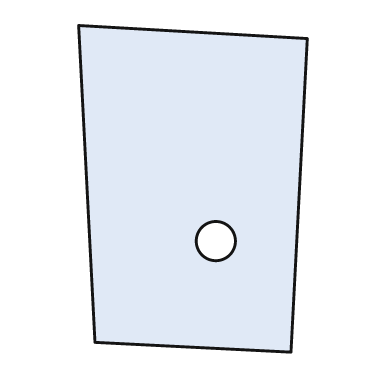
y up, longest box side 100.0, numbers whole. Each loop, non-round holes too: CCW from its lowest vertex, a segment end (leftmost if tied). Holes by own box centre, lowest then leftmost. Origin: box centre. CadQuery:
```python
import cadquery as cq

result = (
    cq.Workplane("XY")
    .moveTo(30.0, -50.0)
    .lineTo(35.0, 46.0)
    .lineTo(-35.0, 50.0)
    .lineTo(-30.0, -47.0)
    .close()
    .moveTo(7.0, -16.0)
    .circle(6.0)
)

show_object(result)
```